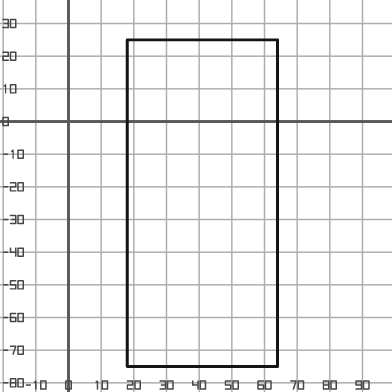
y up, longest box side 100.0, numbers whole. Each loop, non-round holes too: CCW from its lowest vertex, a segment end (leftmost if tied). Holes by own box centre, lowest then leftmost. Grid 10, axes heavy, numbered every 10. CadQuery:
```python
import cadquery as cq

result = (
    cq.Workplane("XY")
    .moveTo(18.0, -75.0)
    .lineTo(64.0, -75.0)
    .lineTo(64.0, 25.0)
    .lineTo(18.0, 25.0)
    .close()
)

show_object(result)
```